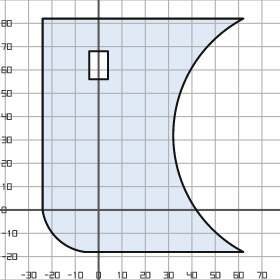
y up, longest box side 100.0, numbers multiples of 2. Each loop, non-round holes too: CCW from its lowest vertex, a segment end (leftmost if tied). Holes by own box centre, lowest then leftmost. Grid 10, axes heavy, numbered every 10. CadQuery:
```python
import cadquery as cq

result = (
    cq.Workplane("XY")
    .moveTo(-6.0, -18.0)
    .lineTo(62.0, -18.0)
    .threePointArc((32.0, 32.0), (62.0, 82.0))
    .lineTo(-24.0, 82.0)
    .lineTo(-24.0, 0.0)
    .threePointArc((-18.0, -12.0), (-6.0, -18.0))
    .close()
    .moveTo(-4.0, 56.0)
    .lineTo(4.0, 56.0)
    .lineTo(4.0, 68.0)
    .lineTo(-4.0, 68.0)
    .close()
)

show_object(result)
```